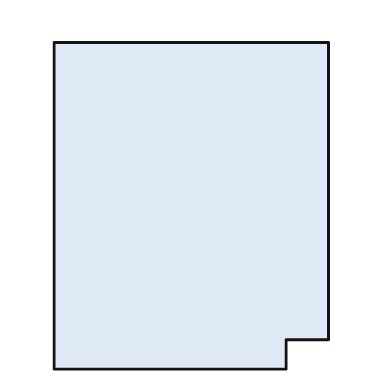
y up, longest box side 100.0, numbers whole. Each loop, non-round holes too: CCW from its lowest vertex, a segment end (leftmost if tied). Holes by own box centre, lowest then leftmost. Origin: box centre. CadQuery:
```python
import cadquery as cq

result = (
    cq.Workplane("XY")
    .moveTo(-42.0, -50.0)
    .lineTo(29.0, -50.0)
    .lineTo(29.0, -41.0)
    .lineTo(42.0, -41.0)
    .lineTo(42.0, 50.0)
    .lineTo(-42.0, 50.0)
    .close()
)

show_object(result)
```